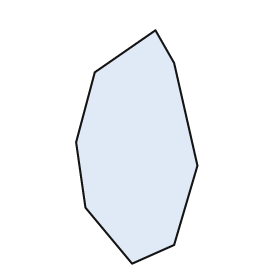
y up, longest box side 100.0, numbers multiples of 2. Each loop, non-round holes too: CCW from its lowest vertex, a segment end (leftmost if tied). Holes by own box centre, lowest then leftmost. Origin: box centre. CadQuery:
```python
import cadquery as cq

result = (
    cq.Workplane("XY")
    .moveTo(-2.0, -50.0)
    .lineTo(16.0, -42.0)
    .lineTo(26.0, -8.0)
    .lineTo(16.0, 36.0)
    .lineTo(8.0, 50.0)
    .lineTo(-18.0, 32.0)
    .lineTo(-26.0, 2.0)
    .lineTo(-22.0, -26.0)
    .close()
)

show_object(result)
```